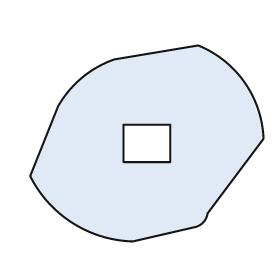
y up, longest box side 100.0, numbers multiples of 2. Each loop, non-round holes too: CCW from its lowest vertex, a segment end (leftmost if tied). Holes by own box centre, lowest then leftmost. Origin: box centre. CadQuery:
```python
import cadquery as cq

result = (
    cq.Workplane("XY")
    .moveTo(-6.0, -42.0)
    .lineTo(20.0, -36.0)
    .threePointArc((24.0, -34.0), (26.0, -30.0))
    .lineTo(50.0, 2.0)
    .threePointArc((42.0, 26.0), (22.0, 42.0))
    .lineTo(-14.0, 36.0)
    .threePointArc((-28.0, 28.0), (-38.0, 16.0))
    .lineTo(-50.0, -14.0)
    .threePointArc((-32.0, -34.0), (-6.0, -42.0))
    .close()
    .moveTo(-10.0, -8.0)
    .lineTo(10.0, -8.0)
    .lineTo(10.0, 8.0)
    .lineTo(-10.0, 8.0)
    .close()
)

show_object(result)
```